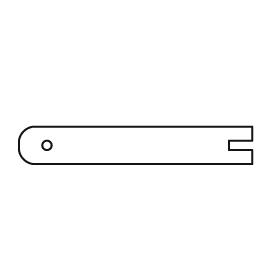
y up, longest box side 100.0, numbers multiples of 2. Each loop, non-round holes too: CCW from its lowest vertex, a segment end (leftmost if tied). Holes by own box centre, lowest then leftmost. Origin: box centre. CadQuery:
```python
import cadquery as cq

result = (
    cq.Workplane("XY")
    .moveTo(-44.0, -8.0)
    .lineTo(50.0, -8.0)
    .lineTo(50.0, -2.0)
    .lineTo(40.0, -2.0)
    .lineTo(40.0, 2.0)
    .lineTo(50.0, 2.0)
    .lineTo(50.0, 8.0)
    .lineTo(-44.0, 8.0)
    .threePointArc((-48.0, 6.0), (-50.0, 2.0))
    .lineTo(-50.0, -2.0)
    .threePointArc((-48.0, -6.0), (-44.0, -8.0))
    .close()
    .moveTo(-38.0, 0.0)
    .circle(2.0)
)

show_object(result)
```